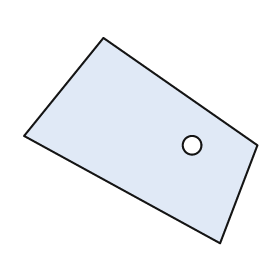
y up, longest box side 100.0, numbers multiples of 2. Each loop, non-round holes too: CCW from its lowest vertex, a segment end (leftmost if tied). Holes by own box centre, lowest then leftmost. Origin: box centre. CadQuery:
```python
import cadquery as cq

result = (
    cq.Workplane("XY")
    .moveTo(34.0, -44.0)
    .lineTo(50.0, -2.0)
    .lineTo(-16.0, 44.0)
    .lineTo(-50.0, 2.0)
    .close()
    .moveTo(22.0, -2.0)
    .circle(4.0)
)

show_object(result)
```